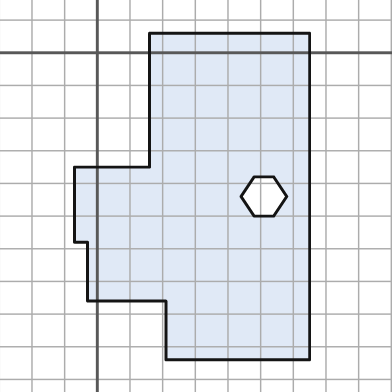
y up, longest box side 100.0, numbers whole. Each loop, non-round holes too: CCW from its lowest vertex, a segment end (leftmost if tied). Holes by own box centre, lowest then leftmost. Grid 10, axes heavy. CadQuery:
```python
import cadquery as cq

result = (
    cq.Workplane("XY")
    .moveTo(21.0, -94.0)
    .lineTo(65.0, -94.0)
    .lineTo(65.0, 6.0)
    .lineTo(16.0, 6.0)
    .lineTo(16.0, -35.0)
    .lineTo(-7.0, -35.0)
    .lineTo(-7.0, -58.0)
    .lineTo(-3.0, -58.0)
    .lineTo(-3.0, -76.0)
    .lineTo(21.0, -76.0)
    .close()
    .moveTo(48.0, -50.0)
    .lineTo(54.0, -50.0)
    .lineTo(58.0, -44.0)
    .lineTo(54.0, -38.0)
    .lineTo(48.0, -38.0)
    .lineTo(44.0, -44.0)
    .close()
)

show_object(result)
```